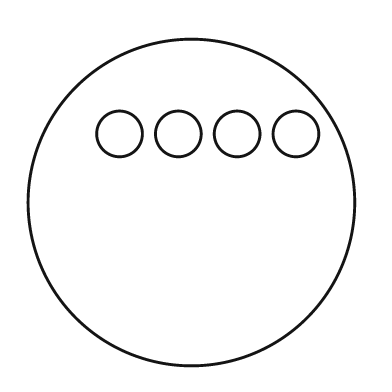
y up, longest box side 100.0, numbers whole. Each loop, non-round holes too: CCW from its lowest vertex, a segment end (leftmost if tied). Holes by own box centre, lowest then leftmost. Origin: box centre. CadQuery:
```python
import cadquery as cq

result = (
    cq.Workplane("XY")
    .moveTo(0.0, 0.0)
    .circle(50.0)
    .moveTo(-22.0, 21.0)
    .circle(7.0)
    .moveTo(-4.0, 21.0)
    .circle(7.0)
    .moveTo(14.0, 21.0)
    .circle(7.0)
    .moveTo(32.0, 21.0)
    .circle(7.0)
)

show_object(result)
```